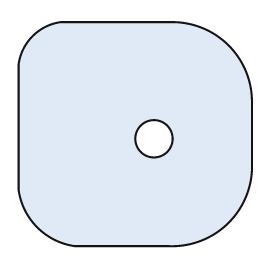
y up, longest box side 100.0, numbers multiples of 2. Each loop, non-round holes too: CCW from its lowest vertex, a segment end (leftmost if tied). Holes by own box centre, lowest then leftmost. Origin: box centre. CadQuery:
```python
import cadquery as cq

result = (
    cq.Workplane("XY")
    .moveTo(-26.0, -48.0)
    .lineTo(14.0, -48.0)
    .threePointArc((40.0, -38.0), (50.0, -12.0))
    .lineTo(50.0, 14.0)
    .threePointArc((40.0, 38.0), (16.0, 48.0))
    .lineTo(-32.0, 48.0)
    .threePointArc((-44.0, 42.0), (-50.0, 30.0))
    .lineTo(-50.0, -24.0)
    .threePointArc((-42.0, -40.0), (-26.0, -48.0))
    .close()
    .moveTo(8.0, -2.0)
    .circle(8.0)
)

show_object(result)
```